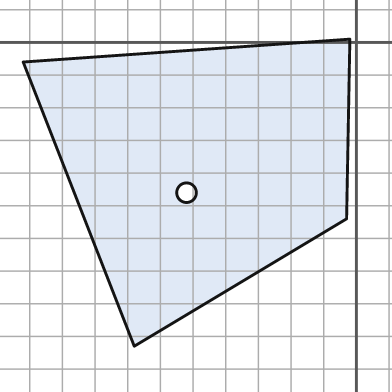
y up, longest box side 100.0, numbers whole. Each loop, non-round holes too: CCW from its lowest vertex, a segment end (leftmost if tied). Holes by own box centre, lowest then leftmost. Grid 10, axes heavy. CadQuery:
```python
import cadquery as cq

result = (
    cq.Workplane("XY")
    .moveTo(-68.0, -93.0)
    .lineTo(-3.0, -54.0)
    .lineTo(-2.0, 1.0)
    .lineTo(-102.0, -6.0)
    .close()
    .moveTo(-52.0, -46.0)
    .circle(3.0)
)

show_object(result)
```